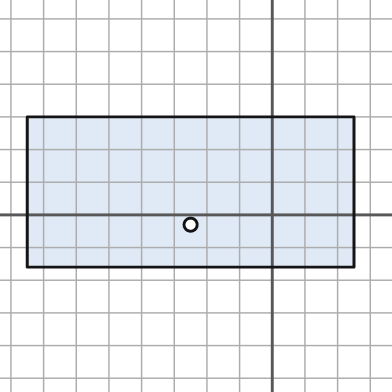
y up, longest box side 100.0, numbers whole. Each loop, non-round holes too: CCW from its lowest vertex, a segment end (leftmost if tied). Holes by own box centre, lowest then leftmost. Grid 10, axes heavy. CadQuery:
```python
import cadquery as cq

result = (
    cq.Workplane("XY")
    .moveTo(-75.0, -16.0)
    .lineTo(25.0, -16.0)
    .lineTo(25.0, 30.0)
    .lineTo(-75.0, 30.0)
    .close()
    .moveTo(-25.0, -3.0)
    .circle(2.0)
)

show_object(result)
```